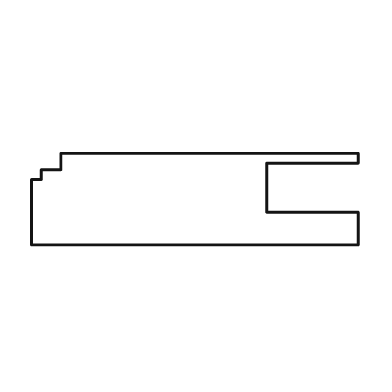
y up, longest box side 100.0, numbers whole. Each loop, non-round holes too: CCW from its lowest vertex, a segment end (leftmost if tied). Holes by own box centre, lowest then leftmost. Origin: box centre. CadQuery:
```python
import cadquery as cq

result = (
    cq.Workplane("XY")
    .moveTo(-50.0, -14.0)
    .lineTo(50.0, -14.0)
    .lineTo(50.0, -4.0)
    .lineTo(22.0, -4.0)
    .lineTo(22.0, 11.0)
    .lineTo(50.0, 11.0)
    .lineTo(50.0, 14.0)
    .lineTo(-41.0, 14.0)
    .lineTo(-41.0, 9.0)
    .lineTo(-47.0, 9.0)
    .lineTo(-47.0, 6.0)
    .lineTo(-50.0, 6.0)
    .close()
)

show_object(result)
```